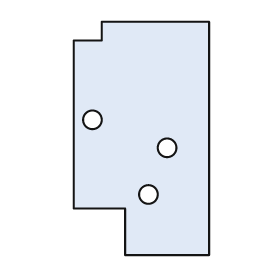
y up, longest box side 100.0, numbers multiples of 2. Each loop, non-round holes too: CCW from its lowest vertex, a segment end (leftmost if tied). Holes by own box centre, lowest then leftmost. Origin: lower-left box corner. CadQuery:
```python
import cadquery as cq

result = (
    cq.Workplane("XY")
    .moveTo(22.0, 0.0)
    .lineTo(58.0, 0.0)
    .lineTo(58.0, 100.0)
    .lineTo(12.0, 100.0)
    .lineTo(12.0, 92.0)
    .lineTo(0.0, 92.0)
    .lineTo(0.0, 20.0)
    .lineTo(22.0, 20.0)
    .close()
    .moveTo(32.0, 26.0)
    .circle(4.0)
    .moveTo(40.0, 46.0)
    .circle(4.0)
    .moveTo(8.0, 58.0)
    .circle(4.0)
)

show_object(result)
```